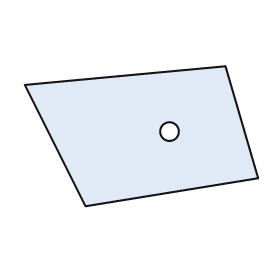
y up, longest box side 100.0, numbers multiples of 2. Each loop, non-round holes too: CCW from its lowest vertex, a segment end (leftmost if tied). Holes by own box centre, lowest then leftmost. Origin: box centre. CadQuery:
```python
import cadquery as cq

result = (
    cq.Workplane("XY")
    .moveTo(-24.0, -30.0)
    .lineTo(50.0, -18.0)
    .lineTo(36.0, 30.0)
    .lineTo(-50.0, 22.0)
    .close()
    .moveTo(12.0, 2.0)
    .circle(4.0)
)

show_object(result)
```